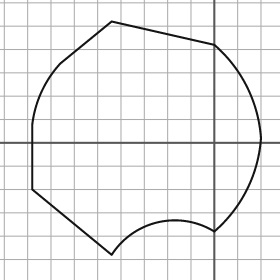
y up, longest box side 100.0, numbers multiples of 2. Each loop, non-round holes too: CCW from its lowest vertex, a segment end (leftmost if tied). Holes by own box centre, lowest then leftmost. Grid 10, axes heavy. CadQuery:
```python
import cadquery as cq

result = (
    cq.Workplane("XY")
    .moveTo(-44.0, -48.0)
    .threePointArc((-24.0, -34.0), (0.0, -38.0))
    .threePointArc((14.0, -20.0), (20.0, 2.0))
    .threePointArc((14.0, 24.0), (0.0, 42.0))
    .lineTo(-44.0, 52.0)
    .lineTo(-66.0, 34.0)
    .threePointArc((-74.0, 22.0), (-78.0, 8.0))
    .lineTo(-78.0, -20.0)
    .close()
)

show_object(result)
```